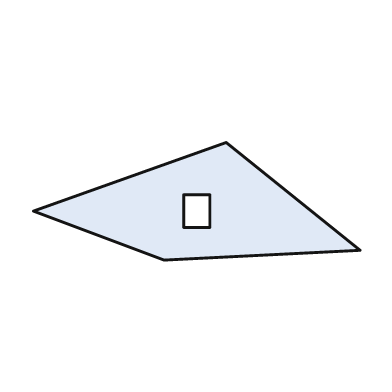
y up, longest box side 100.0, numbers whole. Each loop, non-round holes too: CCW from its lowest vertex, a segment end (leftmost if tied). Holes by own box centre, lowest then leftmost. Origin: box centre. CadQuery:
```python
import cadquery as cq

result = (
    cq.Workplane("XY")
    .moveTo(-10.0, -18.0)
    .lineTo(50.0, -15.0)
    .lineTo(9.0, 18.0)
    .lineTo(-50.0, -3.0)
    .close()
    .moveTo(-4.0, -8.0)
    .lineTo(4.0, -8.0)
    .lineTo(4.0, 2.0)
    .lineTo(-4.0, 2.0)
    .close()
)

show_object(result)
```